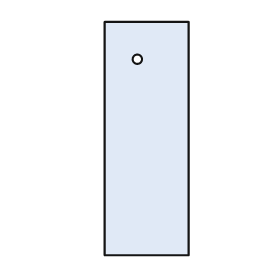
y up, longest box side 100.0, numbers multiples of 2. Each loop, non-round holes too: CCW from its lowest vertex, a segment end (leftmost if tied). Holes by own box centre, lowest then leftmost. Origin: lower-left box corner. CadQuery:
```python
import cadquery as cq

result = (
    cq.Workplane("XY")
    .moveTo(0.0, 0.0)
    .lineTo(36.0, 0.0)
    .lineTo(36.0, 100.0)
    .lineTo(0.0, 100.0)
    .close()
    .moveTo(14.0, 84.0)
    .circle(2.0)
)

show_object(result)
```